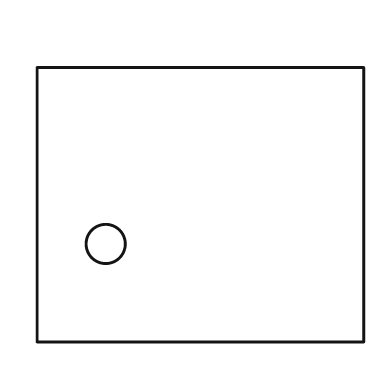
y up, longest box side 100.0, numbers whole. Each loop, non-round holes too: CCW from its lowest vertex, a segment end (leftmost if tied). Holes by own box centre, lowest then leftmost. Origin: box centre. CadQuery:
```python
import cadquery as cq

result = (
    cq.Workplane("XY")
    .moveTo(-50.0, -42.0)
    .lineTo(50.0, -42.0)
    .lineTo(50.0, 42.0)
    .lineTo(-50.0, 42.0)
    .close()
    .moveTo(-29.0, -12.0)
    .circle(6.0)
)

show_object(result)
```